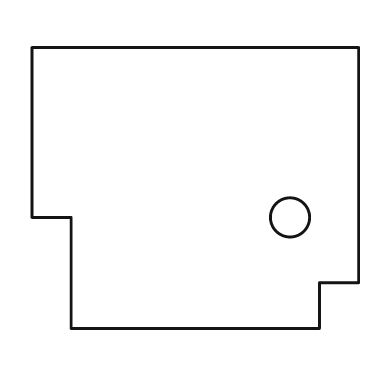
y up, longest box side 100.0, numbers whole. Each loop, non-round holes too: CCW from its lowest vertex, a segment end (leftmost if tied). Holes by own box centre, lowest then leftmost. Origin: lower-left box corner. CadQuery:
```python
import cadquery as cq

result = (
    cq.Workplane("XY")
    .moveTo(12.0, 0.0)
    .lineTo(88.0, 0.0)
    .lineTo(88.0, 14.0)
    .lineTo(100.0, 14.0)
    .lineTo(100.0, 86.0)
    .lineTo(0.0, 86.0)
    .lineTo(0.0, 34.0)
    .lineTo(12.0, 34.0)
    .close()
    .moveTo(79.0, 34.0)
    .circle(6.0)
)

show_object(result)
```